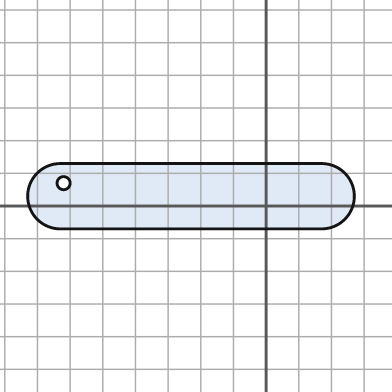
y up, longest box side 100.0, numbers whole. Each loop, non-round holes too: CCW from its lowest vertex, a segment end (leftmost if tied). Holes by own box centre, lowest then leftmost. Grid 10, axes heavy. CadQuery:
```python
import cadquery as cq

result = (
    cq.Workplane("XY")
    .moveTo(-63.0, -7.0)
    .lineTo(17.0, -7.0)
    .threePointArc((27.0, 3.0), (17.0, 13.0))
    .lineTo(-63.0, 13.0)
    .threePointArc((-73.0, 3.0), (-63.0, -7.0))
    .close()
    .moveTo(-62.0, 7.0)
    .circle(2.0)
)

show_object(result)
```